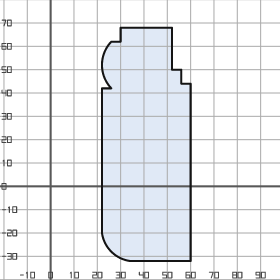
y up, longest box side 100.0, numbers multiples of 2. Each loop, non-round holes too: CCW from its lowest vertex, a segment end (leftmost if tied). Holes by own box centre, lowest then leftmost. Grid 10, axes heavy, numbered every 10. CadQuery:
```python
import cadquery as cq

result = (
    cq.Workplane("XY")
    .moveTo(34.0, -32.0)
    .lineTo(60.0, -32.0)
    .lineTo(60.0, 44.0)
    .lineTo(56.0, 44.0)
    .lineTo(56.0, 50.0)
    .lineTo(52.0, 50.0)
    .lineTo(52.0, 68.0)
    .lineTo(30.0, 68.0)
    .lineTo(30.0, 62.0)
    .lineTo(26.0, 62.0)
    .threePointArc((22.0, 52.0), (26.0, 42.0))
    .lineTo(22.0, 42.0)
    .lineTo(22.0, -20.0)
    .threePointArc((26.0, -28.0), (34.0, -32.0))
    .close()
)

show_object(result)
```